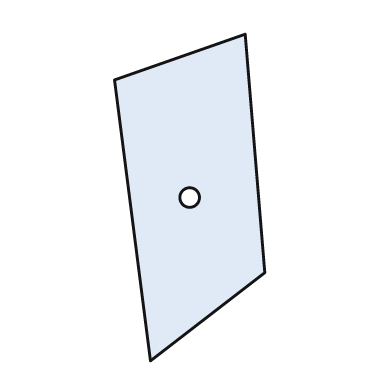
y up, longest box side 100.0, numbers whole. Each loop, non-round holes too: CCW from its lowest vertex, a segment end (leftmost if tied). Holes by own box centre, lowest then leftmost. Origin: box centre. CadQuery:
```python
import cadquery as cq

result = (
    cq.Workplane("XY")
    .moveTo(-12.0, -50.0)
    .lineTo(23.0, -23.0)
    .lineTo(17.0, 50.0)
    .lineTo(-23.0, 36.0)
    .close()
    .moveTo(0.0, 0.0)
    .circle(3.0)
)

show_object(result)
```